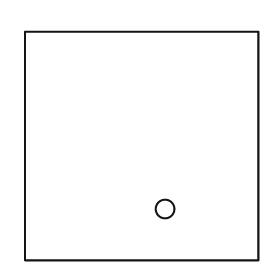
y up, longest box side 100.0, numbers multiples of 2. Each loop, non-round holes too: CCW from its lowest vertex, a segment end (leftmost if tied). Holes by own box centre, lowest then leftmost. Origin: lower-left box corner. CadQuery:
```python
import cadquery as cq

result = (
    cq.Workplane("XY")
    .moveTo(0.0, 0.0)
    .lineTo(100.0, 0.0)
    .lineTo(100.0, 98.0)
    .lineTo(0.0, 98.0)
    .close()
    .moveTo(60.0, 22.0)
    .circle(4.0)
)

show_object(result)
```